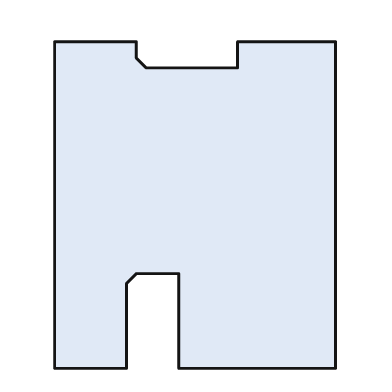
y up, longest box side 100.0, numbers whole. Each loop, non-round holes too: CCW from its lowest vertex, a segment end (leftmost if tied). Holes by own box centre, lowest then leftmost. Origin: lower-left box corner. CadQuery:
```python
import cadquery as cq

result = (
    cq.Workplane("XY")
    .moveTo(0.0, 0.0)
    .lineTo(22.0, 0.0)
    .lineTo(22.0, 26.0)
    .lineTo(25.0, 29.0)
    .lineTo(38.0, 29.0)
    .lineTo(38.0, 0.0)
    .lineTo(86.0, 0.0)
    .lineTo(86.0, 100.0)
    .lineTo(56.0, 100.0)
    .lineTo(56.0, 92.0)
    .lineTo(28.0, 92.0)
    .lineTo(25.0, 95.0)
    .lineTo(25.0, 100.0)
    .lineTo(0.0, 100.0)
    .close()
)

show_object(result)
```